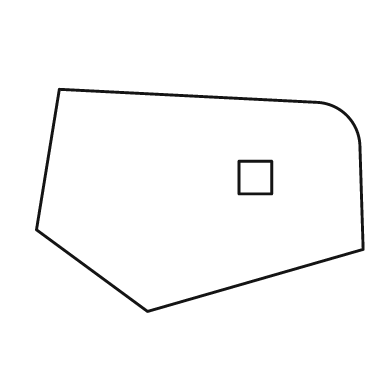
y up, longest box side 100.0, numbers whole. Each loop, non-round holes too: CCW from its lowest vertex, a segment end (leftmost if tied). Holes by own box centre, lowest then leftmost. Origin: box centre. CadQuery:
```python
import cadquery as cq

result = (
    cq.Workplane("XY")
    .moveTo(-16.0, -34.0)
    .lineTo(50.0, -15.0)
    .lineTo(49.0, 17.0)
    .threePointArc((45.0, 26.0), (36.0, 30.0))
    .lineTo(-43.0, 34.0)
    .lineTo(-50.0, -9.0)
    .close()
    .moveTo(12.0, 2.0)
    .lineTo(22.0, 2.0)
    .lineTo(22.0, 12.0)
    .lineTo(12.0, 12.0)
    .close()
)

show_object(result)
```